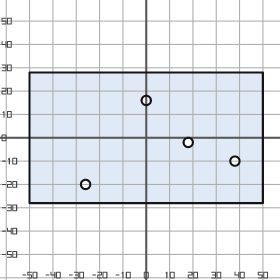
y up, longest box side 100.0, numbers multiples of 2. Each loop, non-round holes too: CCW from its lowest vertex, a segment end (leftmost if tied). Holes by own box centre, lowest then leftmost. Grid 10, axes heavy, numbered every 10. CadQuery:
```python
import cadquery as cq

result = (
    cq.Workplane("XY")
    .moveTo(-50.0, -28.0)
    .lineTo(50.0, -28.0)
    .lineTo(50.0, 28.0)
    .lineTo(-50.0, 28.0)
    .close()
    .moveTo(-26.0, -20.0)
    .circle(2.0)
    .moveTo(38.0, -10.0)
    .circle(2.0)
    .moveTo(18.0, -2.0)
    .circle(2.0)
    .moveTo(0.0, 16.0)
    .circle(2.0)
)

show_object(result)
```